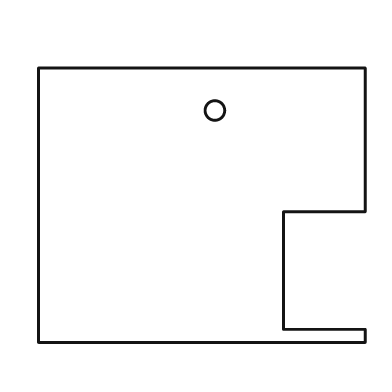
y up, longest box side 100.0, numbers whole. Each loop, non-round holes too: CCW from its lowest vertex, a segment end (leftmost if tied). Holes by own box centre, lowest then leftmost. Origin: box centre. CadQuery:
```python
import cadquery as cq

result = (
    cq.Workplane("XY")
    .moveTo(-50.0, -42.0)
    .lineTo(50.0, -42.0)
    .lineTo(50.0, -38.0)
    .lineTo(25.0, -38.0)
    .lineTo(25.0, -2.0)
    .lineTo(50.0, -2.0)
    .lineTo(50.0, 42.0)
    .lineTo(-50.0, 42.0)
    .close()
    .moveTo(4.0, 29.0)
    .circle(3.0)
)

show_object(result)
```